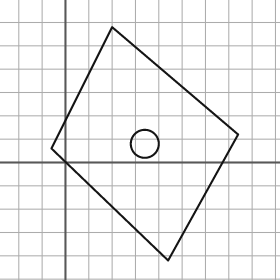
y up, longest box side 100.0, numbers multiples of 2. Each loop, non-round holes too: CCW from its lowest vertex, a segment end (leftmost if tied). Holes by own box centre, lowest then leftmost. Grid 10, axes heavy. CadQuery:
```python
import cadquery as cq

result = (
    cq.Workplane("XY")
    .moveTo(44.0, -42.0)
    .lineTo(74.0, 12.0)
    .lineTo(20.0, 58.0)
    .lineTo(-6.0, 6.0)
    .close()
    .moveTo(34.0, 8.0)
    .circle(6.0)
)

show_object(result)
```